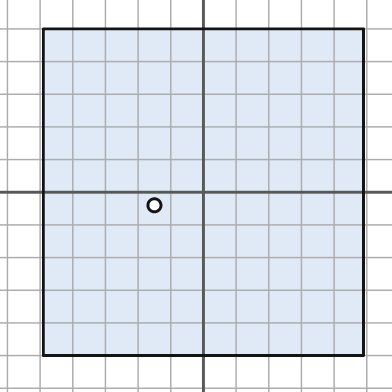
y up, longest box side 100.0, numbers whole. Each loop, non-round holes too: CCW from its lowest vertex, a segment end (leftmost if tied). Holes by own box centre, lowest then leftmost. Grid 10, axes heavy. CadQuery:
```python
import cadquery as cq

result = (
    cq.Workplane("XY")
    .moveTo(-49.0, -50.0)
    .lineTo(49.0, -50.0)
    .lineTo(49.0, 50.0)
    .lineTo(-49.0, 50.0)
    .close()
    .moveTo(-15.0, -4.0)
    .circle(2.0)
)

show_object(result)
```